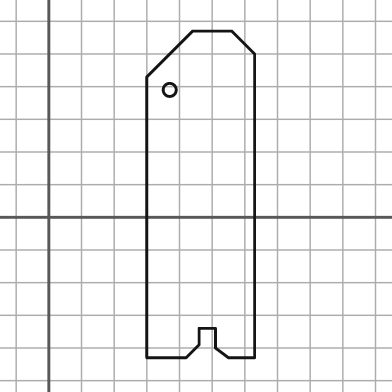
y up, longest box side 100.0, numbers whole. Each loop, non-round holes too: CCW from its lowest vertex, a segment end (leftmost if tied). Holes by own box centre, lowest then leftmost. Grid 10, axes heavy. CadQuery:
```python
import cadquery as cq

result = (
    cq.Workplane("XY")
    .moveTo(30.0, -43.0)
    .lineTo(42.0, -43.0)
    .lineTo(46.0, -39.0)
    .lineTo(46.0, -34.0)
    .lineTo(51.0, -34.0)
    .lineTo(51.0, -40.0)
    .lineTo(55.0, -43.0)
    .lineTo(63.0, -43.0)
    .lineTo(63.0, 50.0)
    .lineTo(56.0, 57.0)
    .lineTo(44.0, 57.0)
    .lineTo(30.0, 43.0)
    .close()
    .moveTo(37.0, 39.0)
    .circle(2.0)
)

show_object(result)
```